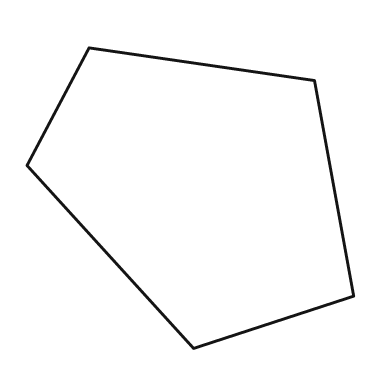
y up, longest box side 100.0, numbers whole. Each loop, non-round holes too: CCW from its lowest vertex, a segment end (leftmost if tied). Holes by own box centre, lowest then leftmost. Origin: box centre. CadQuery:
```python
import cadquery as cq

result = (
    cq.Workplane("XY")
    .moveTo(1.0, -46.0)
    .lineTo(50.0, -30.0)
    .lineTo(38.0, 36.0)
    .lineTo(-31.0, 46.0)
    .lineTo(-50.0, 10.0)
    .close()
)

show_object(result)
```